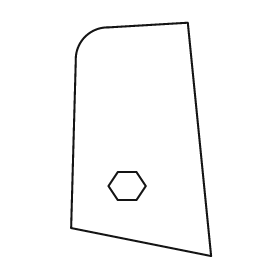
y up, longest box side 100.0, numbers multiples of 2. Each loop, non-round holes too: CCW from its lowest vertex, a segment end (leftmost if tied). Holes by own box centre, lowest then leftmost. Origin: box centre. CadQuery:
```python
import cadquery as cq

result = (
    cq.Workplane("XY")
    .moveTo(30.0, -50.0)
    .lineTo(20.0, 50.0)
    .lineTo(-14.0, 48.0)
    .threePointArc((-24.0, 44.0), (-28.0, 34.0))
    .lineTo(-30.0, -38.0)
    .close()
    .moveTo(-10.0, -26.0)
    .lineTo(-2.0, -26.0)
    .lineTo(2.0, -20.0)
    .lineTo(-2.0, -14.0)
    .lineTo(-10.0, -14.0)
    .lineTo(-14.0, -20.0)
    .close()
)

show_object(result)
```